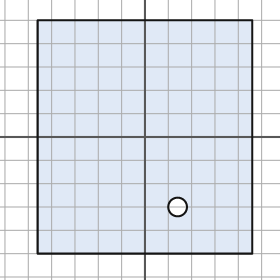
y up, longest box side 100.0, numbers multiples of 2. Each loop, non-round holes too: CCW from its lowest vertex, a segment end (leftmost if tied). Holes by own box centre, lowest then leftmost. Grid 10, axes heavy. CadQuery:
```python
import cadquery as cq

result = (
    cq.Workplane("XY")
    .moveTo(-46.0, -50.0)
    .lineTo(46.0, -50.0)
    .lineTo(46.0, 50.0)
    .lineTo(-46.0, 50.0)
    .close()
    .moveTo(14.0, -30.0)
    .circle(4.0)
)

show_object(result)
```